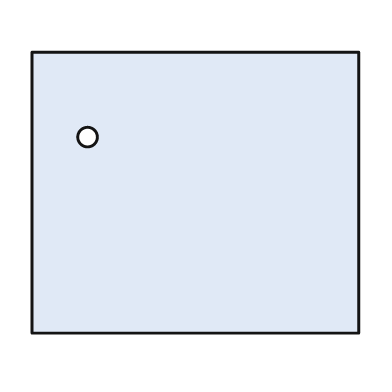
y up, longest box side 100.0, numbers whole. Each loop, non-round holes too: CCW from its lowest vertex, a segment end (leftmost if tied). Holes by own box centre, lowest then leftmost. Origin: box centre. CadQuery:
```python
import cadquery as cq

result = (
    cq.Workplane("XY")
    .moveTo(-50.0, -43.0)
    .lineTo(50.0, -43.0)
    .lineTo(50.0, 43.0)
    .lineTo(-50.0, 43.0)
    .close()
    .moveTo(-33.0, 17.0)
    .circle(3.0)
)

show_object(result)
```